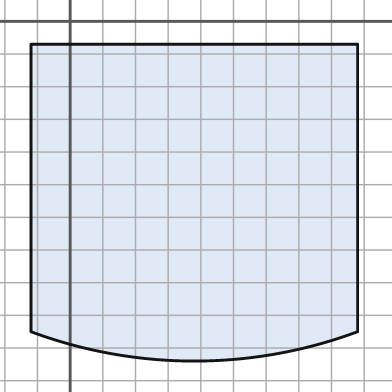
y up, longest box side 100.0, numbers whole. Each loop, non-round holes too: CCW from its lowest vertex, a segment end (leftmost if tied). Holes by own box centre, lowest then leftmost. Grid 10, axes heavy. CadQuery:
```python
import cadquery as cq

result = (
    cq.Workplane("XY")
    .moveTo(-12.0, -95.0)
    .threePointArc((38.0, -104.0), (88.0, -95.0))
    .lineTo(88.0, -7.0)
    .lineTo(-12.0, -7.0)
    .close()
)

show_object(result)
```